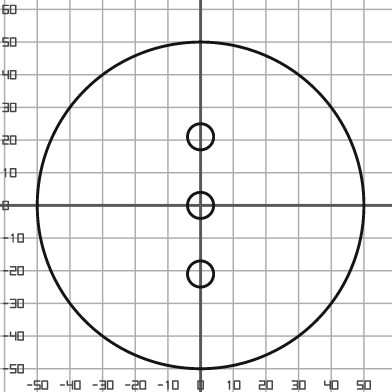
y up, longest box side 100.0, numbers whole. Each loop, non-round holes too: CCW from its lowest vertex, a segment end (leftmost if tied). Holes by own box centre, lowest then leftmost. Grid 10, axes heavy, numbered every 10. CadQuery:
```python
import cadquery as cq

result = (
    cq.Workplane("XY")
    .moveTo(0.0, 0.0)
    .circle(50.0)
    .moveTo(0.0, -21.0)
    .circle(4.0)
    .moveTo(0.0, 0.0)
    .circle(4.0)
    .moveTo(0.0, 21.0)
    .circle(4.0)
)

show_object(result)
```